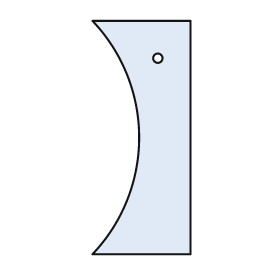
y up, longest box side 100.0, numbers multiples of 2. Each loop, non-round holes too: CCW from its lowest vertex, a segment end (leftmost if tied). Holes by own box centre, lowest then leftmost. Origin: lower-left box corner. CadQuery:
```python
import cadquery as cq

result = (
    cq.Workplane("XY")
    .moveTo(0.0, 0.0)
    .lineTo(42.0, 0.0)
    .lineTo(42.0, 100.0)
    .lineTo(0.0, 100.0)
    .threePointArc((20.0, 50.0), (0.0, 0.0))
    .close()
    .moveTo(28.0, 84.0)
    .circle(2.0)
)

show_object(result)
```